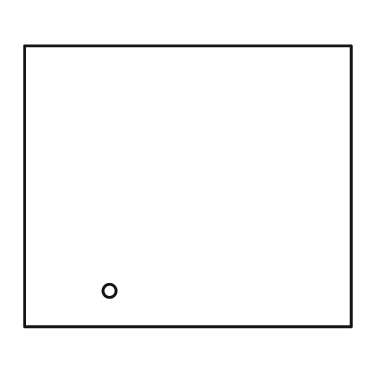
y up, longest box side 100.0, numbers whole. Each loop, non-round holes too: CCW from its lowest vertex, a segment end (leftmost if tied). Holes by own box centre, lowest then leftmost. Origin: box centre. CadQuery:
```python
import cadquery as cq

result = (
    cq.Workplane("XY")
    .moveTo(-50.0, -43.0)
    .lineTo(50.0, -43.0)
    .lineTo(50.0, 43.0)
    .lineTo(-50.0, 43.0)
    .close()
    .moveTo(-24.0, -32.0)
    .circle(2.0)
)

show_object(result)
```